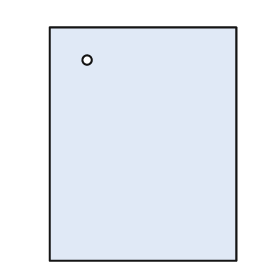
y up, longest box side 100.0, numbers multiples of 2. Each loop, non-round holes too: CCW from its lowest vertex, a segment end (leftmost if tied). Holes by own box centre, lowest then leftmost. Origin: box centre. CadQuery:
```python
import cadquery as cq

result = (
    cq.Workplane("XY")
    .moveTo(-40.0, -50.0)
    .lineTo(40.0, -50.0)
    .lineTo(40.0, 50.0)
    .lineTo(-40.0, 50.0)
    .close()
    .moveTo(-24.0, 36.0)
    .circle(2.0)
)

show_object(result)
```